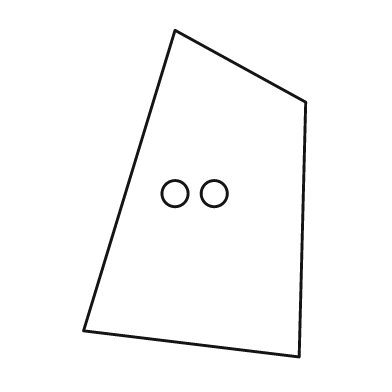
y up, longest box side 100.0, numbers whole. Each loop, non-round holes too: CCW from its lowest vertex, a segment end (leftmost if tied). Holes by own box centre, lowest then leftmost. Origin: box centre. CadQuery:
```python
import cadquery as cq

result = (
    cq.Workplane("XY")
    .moveTo(32.0, -50.0)
    .lineTo(34.0, 28.0)
    .lineTo(-6.0, 50.0)
    .lineTo(-34.0, -42.0)
    .close()
    .moveTo(-6.0, 0.0)
    .circle(4.0)
    .moveTo(6.0, 0.0)
    .circle(4.0)
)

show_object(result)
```